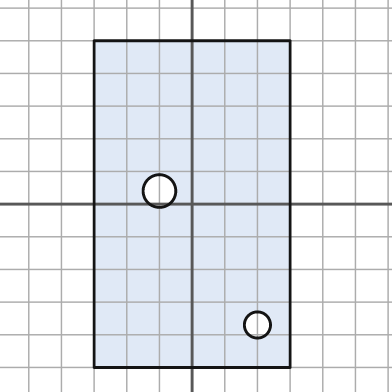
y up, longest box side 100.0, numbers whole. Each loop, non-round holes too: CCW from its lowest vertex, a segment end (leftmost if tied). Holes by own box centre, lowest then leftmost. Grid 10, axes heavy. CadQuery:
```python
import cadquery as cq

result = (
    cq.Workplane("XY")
    .moveTo(-30.0, -50.0)
    .lineTo(30.0, -50.0)
    .lineTo(30.0, 50.0)
    .lineTo(-30.0, 50.0)
    .close()
    .moveTo(20.0, -37.0)
    .circle(4.0)
    .moveTo(-10.0, 4.0)
    .circle(5.0)
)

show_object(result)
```